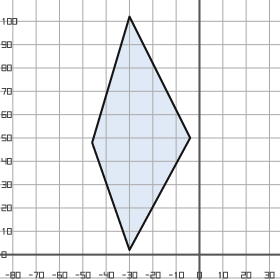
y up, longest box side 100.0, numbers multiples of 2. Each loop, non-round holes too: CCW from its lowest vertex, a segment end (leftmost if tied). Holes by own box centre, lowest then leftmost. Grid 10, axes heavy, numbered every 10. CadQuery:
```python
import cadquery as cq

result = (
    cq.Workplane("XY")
    .moveTo(-30.0, 2.0)
    .lineTo(-4.0, 50.0)
    .lineTo(-30.0, 102.0)
    .lineTo(-46.0, 48.0)
    .close()
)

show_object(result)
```